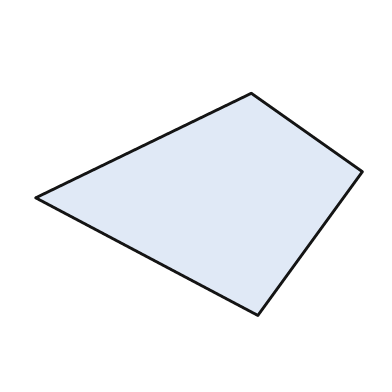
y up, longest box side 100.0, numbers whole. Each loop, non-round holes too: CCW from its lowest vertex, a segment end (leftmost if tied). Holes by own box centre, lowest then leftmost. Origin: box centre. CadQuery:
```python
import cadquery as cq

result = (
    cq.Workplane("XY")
    .moveTo(18.0, -34.0)
    .lineTo(50.0, 10.0)
    .lineTo(16.0, 34.0)
    .lineTo(-50.0, 2.0)
    .close()
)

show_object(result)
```